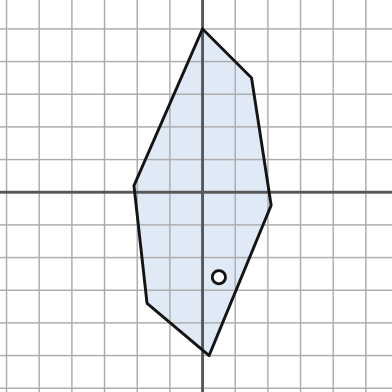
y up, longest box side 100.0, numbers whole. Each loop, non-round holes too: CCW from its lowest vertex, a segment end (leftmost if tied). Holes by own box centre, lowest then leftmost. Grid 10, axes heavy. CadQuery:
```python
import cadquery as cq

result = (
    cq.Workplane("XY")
    .moveTo(2.0, -50.0)
    .lineTo(21.0, -4.0)
    .lineTo(15.0, 35.0)
    .lineTo(0.0, 50.0)
    .lineTo(-21.0, 2.0)
    .lineTo(-17.0, -34.0)
    .close()
    .moveTo(5.0, -26.0)
    .circle(2.0)
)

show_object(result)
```